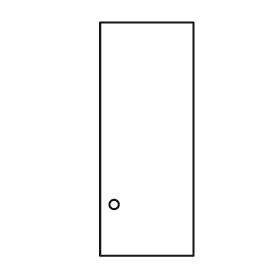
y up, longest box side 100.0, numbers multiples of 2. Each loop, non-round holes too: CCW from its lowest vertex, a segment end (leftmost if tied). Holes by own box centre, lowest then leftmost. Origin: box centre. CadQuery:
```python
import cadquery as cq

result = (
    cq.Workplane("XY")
    .moveTo(-20.0, -50.0)
    .lineTo(20.0, -50.0)
    .lineTo(20.0, 50.0)
    .lineTo(-20.0, 50.0)
    .close()
    .moveTo(-14.0, -28.0)
    .circle(2.0)
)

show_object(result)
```